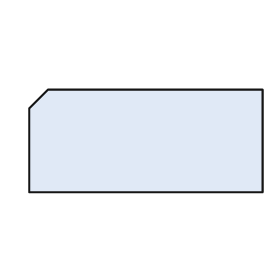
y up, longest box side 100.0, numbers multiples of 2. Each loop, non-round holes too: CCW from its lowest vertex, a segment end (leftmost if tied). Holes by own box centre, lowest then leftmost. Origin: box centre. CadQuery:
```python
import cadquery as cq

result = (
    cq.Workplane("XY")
    .moveTo(-50.0, -22.0)
    .lineTo(50.0, -22.0)
    .lineTo(50.0, 22.0)
    .lineTo(-42.0, 22.0)
    .lineTo(-50.0, 14.0)
    .close()
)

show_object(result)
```